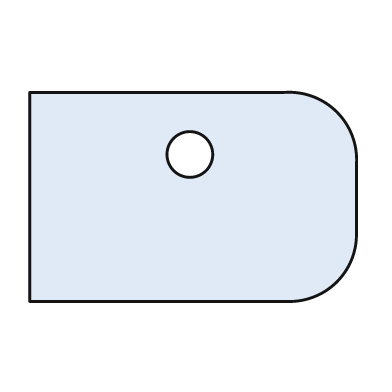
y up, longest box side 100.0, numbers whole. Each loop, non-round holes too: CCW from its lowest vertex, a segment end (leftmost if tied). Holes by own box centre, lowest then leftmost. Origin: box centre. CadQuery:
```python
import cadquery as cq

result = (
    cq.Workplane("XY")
    .moveTo(-50.0, -32.0)
    .lineTo(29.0, -32.0)
    .threePointArc((44.0, -26.0), (50.0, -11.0))
    .lineTo(50.0, 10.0)
    .threePointArc((44.0, 26.0), (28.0, 32.0))
    .lineTo(-50.0, 32.0)
    .close()
    .moveTo(-1.0, 13.0)
    .circle(7.0)
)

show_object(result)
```